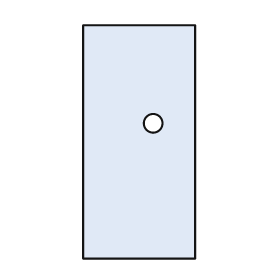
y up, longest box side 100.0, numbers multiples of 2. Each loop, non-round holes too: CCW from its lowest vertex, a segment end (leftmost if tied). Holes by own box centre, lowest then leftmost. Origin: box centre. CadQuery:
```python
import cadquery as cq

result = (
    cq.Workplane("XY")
    .moveTo(-24.0, -50.0)
    .lineTo(24.0, -50.0)
    .lineTo(24.0, 50.0)
    .lineTo(-24.0, 50.0)
    .close()
    .moveTo(6.0, 8.0)
    .circle(4.0)
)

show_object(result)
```